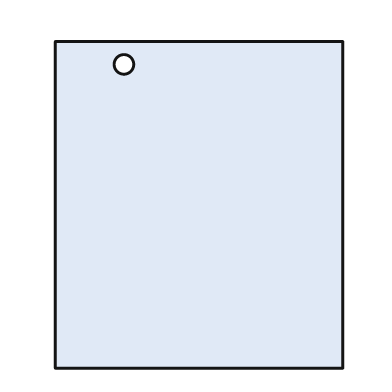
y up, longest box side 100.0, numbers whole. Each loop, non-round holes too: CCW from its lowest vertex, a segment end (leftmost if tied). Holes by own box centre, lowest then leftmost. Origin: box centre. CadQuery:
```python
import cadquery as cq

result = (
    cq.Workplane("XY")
    .moveTo(-44.0, -50.0)
    .lineTo(44.0, -50.0)
    .lineTo(44.0, 50.0)
    .lineTo(-44.0, 50.0)
    .close()
    .moveTo(-23.0, 43.0)
    .circle(3.0)
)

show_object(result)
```